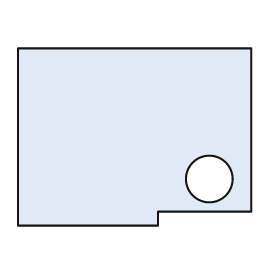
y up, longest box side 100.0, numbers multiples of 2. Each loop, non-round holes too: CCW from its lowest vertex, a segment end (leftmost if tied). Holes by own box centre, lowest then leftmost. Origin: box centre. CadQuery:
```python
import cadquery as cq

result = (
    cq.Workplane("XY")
    .moveTo(-50.0, -38.0)
    .lineTo(10.0, -38.0)
    .lineTo(10.0, -32.0)
    .lineTo(50.0, -32.0)
    .lineTo(50.0, 38.0)
    .lineTo(-50.0, 38.0)
    .close()
    .moveTo(32.0, -18.0)
    .circle(10.0)
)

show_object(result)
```